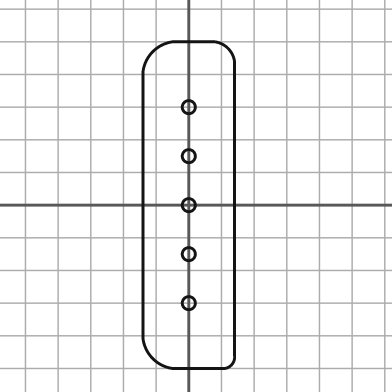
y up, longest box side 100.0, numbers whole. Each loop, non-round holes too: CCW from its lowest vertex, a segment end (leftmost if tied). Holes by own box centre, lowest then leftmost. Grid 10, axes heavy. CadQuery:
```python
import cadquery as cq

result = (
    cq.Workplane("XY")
    .moveTo(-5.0, -50.0)
    .lineTo(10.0, -50.0)
    .threePointArc((13.0, -49.0), (14.0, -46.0))
    .lineTo(14.0, 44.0)
    .threePointArc((12.0, 48.0), (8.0, 50.0))
    .lineTo(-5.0, 50.0)
    .threePointArc((-11.0, 47.0), (-14.0, 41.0))
    .lineTo(-14.0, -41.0)
    .threePointArc((-11.0, -47.0), (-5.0, -50.0))
    .close()
    .moveTo(0.0, -30.0)
    .circle(2.0)
    .moveTo(0.0, -15.0)
    .circle(2.0)
    .moveTo(0.0, 0.0)
    .circle(2.0)
    .moveTo(0.0, 15.0)
    .circle(2.0)
    .moveTo(0.0, 30.0)
    .circle(2.0)
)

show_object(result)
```